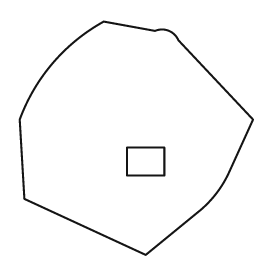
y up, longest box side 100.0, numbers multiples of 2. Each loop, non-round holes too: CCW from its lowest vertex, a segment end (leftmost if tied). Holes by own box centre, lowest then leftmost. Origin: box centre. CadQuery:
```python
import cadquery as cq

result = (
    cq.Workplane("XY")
    .moveTo(4.0, -50.0)
    .lineTo(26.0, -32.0)
    .threePointArc((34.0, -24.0), (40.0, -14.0))
    .lineTo(50.0, 8.0)
    .lineTo(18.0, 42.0)
    .threePointArc((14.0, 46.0), (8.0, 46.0))
    .lineTo(-14.0, 50.0)
    .threePointArc((-36.0, 32.0), (-50.0, 8.0))
    .lineTo(-48.0, -26.0)
    .close()
    .moveTo(-4.0, -16.0)
    .lineTo(12.0, -16.0)
    .lineTo(12.0, -4.0)
    .lineTo(-4.0, -4.0)
    .close()
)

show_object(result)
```